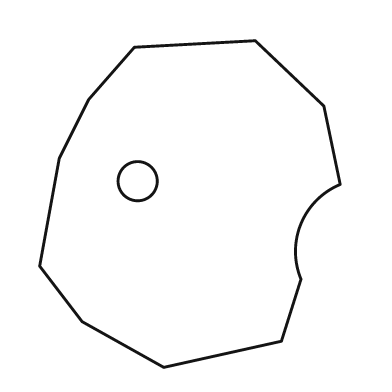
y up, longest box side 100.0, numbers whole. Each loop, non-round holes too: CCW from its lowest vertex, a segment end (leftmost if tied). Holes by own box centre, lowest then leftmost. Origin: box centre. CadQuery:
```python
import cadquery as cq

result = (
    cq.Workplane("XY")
    .moveTo(-8.0, -50.0)
    .lineTo(28.0, -42.0)
    .lineTo(34.0, -23.0)
    .threePointArc((34.0, -6.0), (46.0, 6.0))
    .lineTo(41.0, 30.0)
    .lineTo(20.0, 50.0)
    .lineTo(-17.0, 48.0)
    .lineTo(-31.0, 32.0)
    .lineTo(-40.0, 14.0)
    .lineTo(-46.0, -19.0)
    .lineTo(-33.0, -36.0)
    .close()
    .moveTo(-16.0, 7.0)
    .circle(6.0)
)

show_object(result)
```